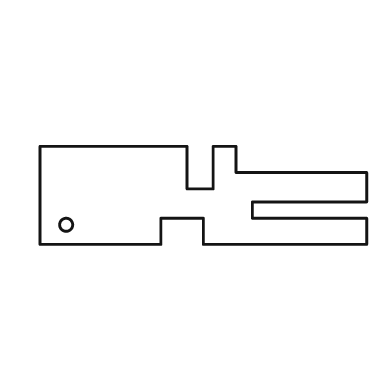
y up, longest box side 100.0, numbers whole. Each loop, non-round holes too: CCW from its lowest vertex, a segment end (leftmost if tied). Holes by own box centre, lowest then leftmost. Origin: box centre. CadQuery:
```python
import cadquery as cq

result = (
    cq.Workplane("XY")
    .moveTo(-50.0, -15.0)
    .lineTo(-13.0, -15.0)
    .lineTo(-13.0, -7.0)
    .lineTo(0.0, -7.0)
    .lineTo(0.0, -15.0)
    .lineTo(50.0, -15.0)
    .lineTo(50.0, -7.0)
    .lineTo(15.0, -7.0)
    .lineTo(15.0, -2.0)
    .lineTo(50.0, -2.0)
    .lineTo(50.0, 7.0)
    .lineTo(10.0, 7.0)
    .lineTo(10.0, 15.0)
    .lineTo(3.0, 15.0)
    .lineTo(3.0, 2.0)
    .lineTo(-5.0, 2.0)
    .lineTo(-5.0, 15.0)
    .lineTo(-50.0, 15.0)
    .close()
    .moveTo(-42.0, -9.0)
    .circle(2.0)
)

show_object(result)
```